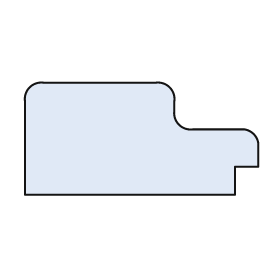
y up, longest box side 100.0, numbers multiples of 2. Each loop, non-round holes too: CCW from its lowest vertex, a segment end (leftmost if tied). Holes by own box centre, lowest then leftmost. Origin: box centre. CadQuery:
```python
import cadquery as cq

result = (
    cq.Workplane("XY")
    .moveTo(-50.0, -24.0)
    .lineTo(40.0, -24.0)
    .lineTo(40.0, -12.0)
    .lineTo(50.0, -12.0)
    .lineTo(50.0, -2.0)
    .threePointArc((48.0, 2.0), (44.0, 4.0))
    .lineTo(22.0, 4.0)
    .threePointArc((16.0, 6.0), (14.0, 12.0))
    .lineTo(14.0, 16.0)
    .threePointArc((12.0, 22.0), (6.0, 24.0))
    .lineTo(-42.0, 24.0)
    .threePointArc((-48.0, 22.0), (-50.0, 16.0))
    .close()
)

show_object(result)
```